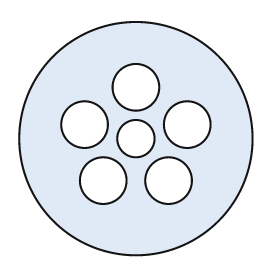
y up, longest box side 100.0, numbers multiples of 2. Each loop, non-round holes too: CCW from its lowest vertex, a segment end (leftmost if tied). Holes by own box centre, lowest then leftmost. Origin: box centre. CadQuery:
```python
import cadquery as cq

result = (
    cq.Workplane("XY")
    .moveTo(0.0, 0.0)
    .circle(50.0)
    .moveTo(-14.0, -18.0)
    .circle(10.0)
    .moveTo(14.0, -18.0)
    .circle(10.0)
    .moveTo(0.0, 0.0)
    .circle(8.0)
    .moveTo(-22.0, 6.0)
    .circle(10.0)
    .moveTo(22.0, 6.0)
    .circle(10.0)
    .moveTo(0.0, 22.0)
    .circle(10.0)
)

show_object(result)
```